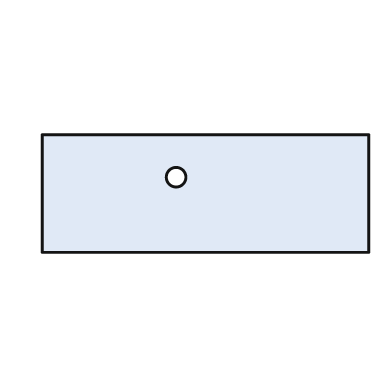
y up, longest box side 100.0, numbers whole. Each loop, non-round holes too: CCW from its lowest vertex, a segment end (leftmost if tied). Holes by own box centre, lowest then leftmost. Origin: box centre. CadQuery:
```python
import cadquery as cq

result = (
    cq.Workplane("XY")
    .moveTo(-50.0, -18.0)
    .lineTo(50.0, -18.0)
    .lineTo(50.0, 18.0)
    .lineTo(-50.0, 18.0)
    .close()
    .moveTo(-9.0, 5.0)
    .circle(3.0)
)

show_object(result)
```